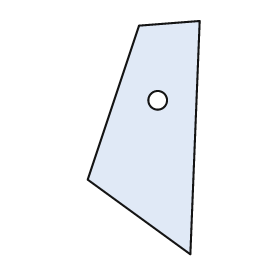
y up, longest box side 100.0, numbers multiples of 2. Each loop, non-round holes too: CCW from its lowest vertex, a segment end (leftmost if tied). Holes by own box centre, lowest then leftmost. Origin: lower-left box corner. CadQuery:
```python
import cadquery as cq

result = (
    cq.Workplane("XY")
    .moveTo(44.0, 0.0)
    .lineTo(48.0, 100.0)
    .lineTo(22.0, 98.0)
    .lineTo(0.0, 32.0)
    .close()
    .moveTo(30.0, 66.0)
    .circle(4.0)
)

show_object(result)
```